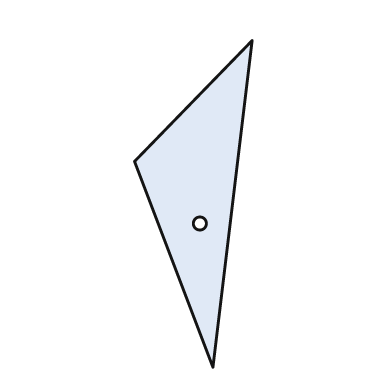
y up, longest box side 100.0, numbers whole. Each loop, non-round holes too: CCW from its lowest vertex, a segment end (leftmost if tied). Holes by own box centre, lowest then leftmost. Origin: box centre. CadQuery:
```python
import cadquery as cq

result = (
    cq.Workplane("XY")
    .moveTo(6.0, -50.0)
    .lineTo(18.0, 50.0)
    .lineTo(-18.0, 13.0)
    .close()
    .moveTo(2.0, -6.0)
    .circle(2.0)
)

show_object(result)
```